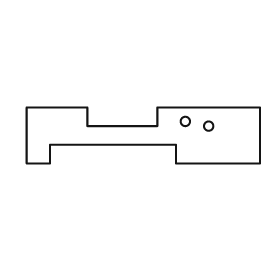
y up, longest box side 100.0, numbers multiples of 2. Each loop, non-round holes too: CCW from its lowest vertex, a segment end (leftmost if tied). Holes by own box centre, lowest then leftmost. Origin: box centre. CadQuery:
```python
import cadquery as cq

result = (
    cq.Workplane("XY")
    .moveTo(-50.0, -12.0)
    .lineTo(-40.0, -12.0)
    .lineTo(-40.0, -4.0)
    .lineTo(14.0, -4.0)
    .lineTo(14.0, -12.0)
    .lineTo(50.0, -12.0)
    .lineTo(50.0, 12.0)
    .lineTo(6.0, 12.0)
    .lineTo(6.0, 4.0)
    .lineTo(-24.0, 4.0)
    .lineTo(-24.0, 12.0)
    .lineTo(-50.0, 12.0)
    .close()
    .moveTo(28.0, 4.0)
    .circle(2.0)
    .moveTo(18.0, 6.0)
    .circle(2.0)
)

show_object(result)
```